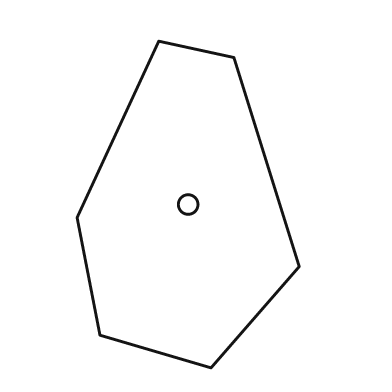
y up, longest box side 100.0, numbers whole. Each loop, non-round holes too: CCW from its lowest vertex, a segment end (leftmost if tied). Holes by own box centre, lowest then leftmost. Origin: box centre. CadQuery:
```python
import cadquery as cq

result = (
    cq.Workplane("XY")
    .moveTo(7.0, -50.0)
    .lineTo(34.0, -19.0)
    .lineTo(14.0, 45.0)
    .lineTo(-9.0, 50.0)
    .lineTo(-34.0, -4.0)
    .lineTo(-27.0, -40.0)
    .close()
    .moveTo(0.0, 0.0)
    .circle(3.0)
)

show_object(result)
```